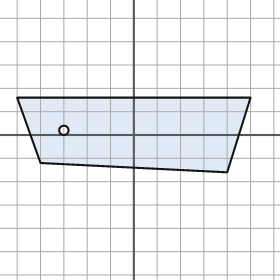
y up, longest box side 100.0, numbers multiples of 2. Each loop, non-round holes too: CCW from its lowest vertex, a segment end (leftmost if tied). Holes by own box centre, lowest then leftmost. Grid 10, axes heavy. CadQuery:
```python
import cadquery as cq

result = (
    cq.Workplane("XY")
    .moveTo(40.0, -16.0)
    .lineTo(50.0, 16.0)
    .lineTo(-50.0, 16.0)
    .lineTo(-40.0, -12.0)
    .close()
    .moveTo(-30.0, 2.0)
    .circle(2.0)
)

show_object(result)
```